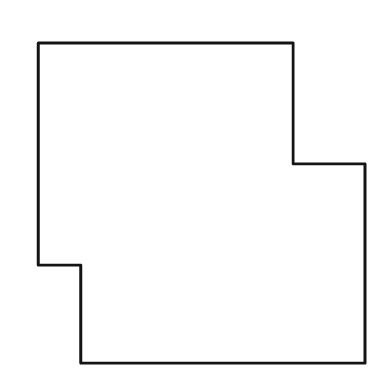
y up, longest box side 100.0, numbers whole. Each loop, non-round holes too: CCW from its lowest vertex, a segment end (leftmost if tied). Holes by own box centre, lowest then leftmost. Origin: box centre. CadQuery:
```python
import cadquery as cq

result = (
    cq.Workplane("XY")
    .moveTo(-37.0, -49.0)
    .lineTo(50.0, -49.0)
    .lineTo(50.0, 12.0)
    .lineTo(28.0, 12.0)
    .lineTo(28.0, 49.0)
    .lineTo(-50.0, 49.0)
    .lineTo(-50.0, -19.0)
    .lineTo(-37.0, -19.0)
    .close()
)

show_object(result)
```